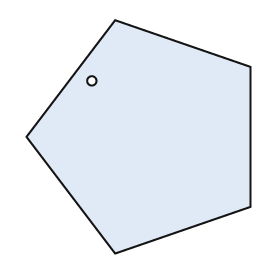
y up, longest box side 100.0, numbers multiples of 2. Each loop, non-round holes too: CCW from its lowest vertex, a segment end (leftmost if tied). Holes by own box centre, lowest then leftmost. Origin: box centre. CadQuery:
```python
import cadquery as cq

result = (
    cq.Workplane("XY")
    .moveTo(-10.0, -50.0)
    .lineTo(48.0, -30.0)
    .lineTo(48.0, 30.0)
    .lineTo(-10.0, 50.0)
    .lineTo(-48.0, 0.0)
    .close()
    .moveTo(-20.0, 24.0)
    .circle(2.0)
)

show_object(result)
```